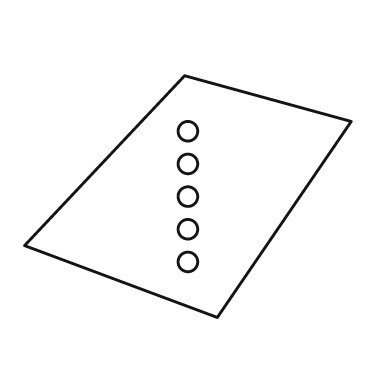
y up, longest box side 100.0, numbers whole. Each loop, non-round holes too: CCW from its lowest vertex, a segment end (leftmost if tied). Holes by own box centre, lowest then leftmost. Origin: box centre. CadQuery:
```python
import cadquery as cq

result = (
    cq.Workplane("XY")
    .moveTo(9.0, -37.0)
    .lineTo(50.0, 23.0)
    .lineTo(-1.0, 37.0)
    .lineTo(-50.0, -15.0)
    .close()
    .moveTo(0.0, -20.0)
    .circle(3.0)
    .moveTo(0.0, -10.0)
    .circle(3.0)
    .moveTo(0.0, 0.0)
    .circle(3.0)
    .moveTo(0.0, 10.0)
    .circle(3.0)
    .moveTo(0.0, 20.0)
    .circle(3.0)
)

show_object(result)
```